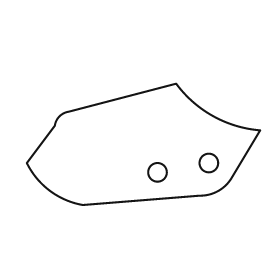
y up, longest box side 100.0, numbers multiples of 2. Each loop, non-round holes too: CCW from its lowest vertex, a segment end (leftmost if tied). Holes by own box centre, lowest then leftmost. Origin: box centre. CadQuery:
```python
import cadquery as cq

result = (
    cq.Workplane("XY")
    .moveTo(-26.0, -26.0)
    .lineTo(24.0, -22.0)
    .threePointArc((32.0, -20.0), (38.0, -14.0))
    .lineTo(50.0, 6.0)
    .threePointArc((30.0, 12.0), (14.0, 26.0))
    .lineTo(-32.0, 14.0)
    .threePointArc((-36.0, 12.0), (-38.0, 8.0))
    .lineTo(-50.0, -8.0)
    .threePointArc((-40.0, -20.0), (-26.0, -26.0))
    .close()
    .moveTo(6.0, -12.0)
    .circle(4.0)
    .moveTo(28.0, -8.0)
    .circle(4.0)
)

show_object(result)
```